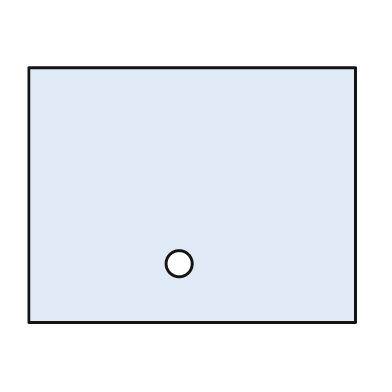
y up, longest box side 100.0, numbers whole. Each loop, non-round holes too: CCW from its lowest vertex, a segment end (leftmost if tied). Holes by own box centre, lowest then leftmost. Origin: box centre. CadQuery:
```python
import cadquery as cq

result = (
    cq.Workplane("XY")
    .moveTo(-50.0, -39.0)
    .lineTo(50.0, -39.0)
    .lineTo(50.0, 39.0)
    .lineTo(-50.0, 39.0)
    .close()
    .moveTo(-4.0, -21.0)
    .circle(4.0)
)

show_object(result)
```